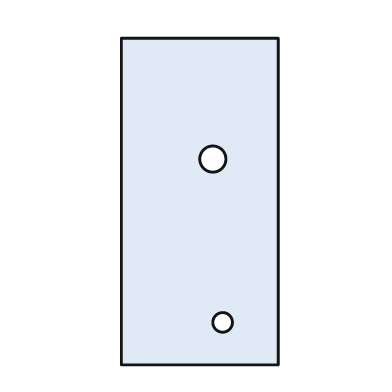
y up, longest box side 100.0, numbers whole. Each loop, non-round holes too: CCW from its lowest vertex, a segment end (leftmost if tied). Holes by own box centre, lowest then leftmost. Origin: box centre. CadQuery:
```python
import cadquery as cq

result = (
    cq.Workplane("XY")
    .moveTo(-24.0, -50.0)
    .lineTo(24.0, -50.0)
    .lineTo(24.0, 50.0)
    .lineTo(-24.0, 50.0)
    .close()
    .moveTo(7.0, -37.0)
    .circle(3.0)
    .moveTo(4.0, 13.0)
    .circle(4.0)
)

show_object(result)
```